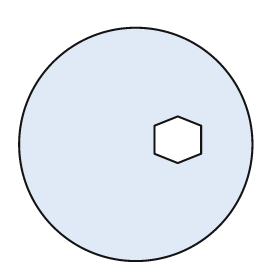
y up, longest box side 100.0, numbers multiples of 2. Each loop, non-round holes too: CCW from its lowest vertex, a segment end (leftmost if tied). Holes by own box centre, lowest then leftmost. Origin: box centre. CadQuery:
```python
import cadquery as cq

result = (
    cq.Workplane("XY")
    .moveTo(0.0, 0.0)
    .circle(50.0)
    .moveTo(18.0, -8.0)
    .lineTo(28.0, -4.0)
    .lineTo(28.0, 8.0)
    .lineTo(18.0, 12.0)
    .lineTo(8.0, 8.0)
    .lineTo(8.0, -4.0)
    .close()
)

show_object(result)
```